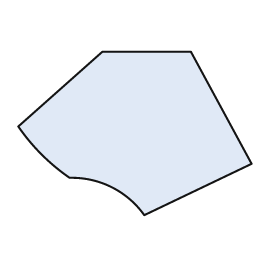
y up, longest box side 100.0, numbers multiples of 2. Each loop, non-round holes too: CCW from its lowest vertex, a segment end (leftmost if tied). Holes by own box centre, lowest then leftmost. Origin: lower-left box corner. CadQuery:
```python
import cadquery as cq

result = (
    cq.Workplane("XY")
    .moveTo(54.0, 0.0)
    .lineTo(100.0, 22.0)
    .lineTo(74.0, 70.0)
    .lineTo(36.0, 70.0)
    .lineTo(0.0, 38.0)
    .threePointArc((10.0, 26.0), (22.0, 16.0))
    .threePointArc((40.0, 12.0), (54.0, 0.0))
    .close()
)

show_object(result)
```